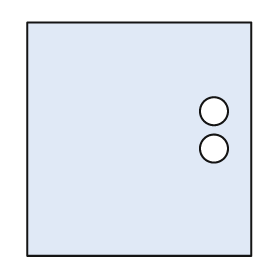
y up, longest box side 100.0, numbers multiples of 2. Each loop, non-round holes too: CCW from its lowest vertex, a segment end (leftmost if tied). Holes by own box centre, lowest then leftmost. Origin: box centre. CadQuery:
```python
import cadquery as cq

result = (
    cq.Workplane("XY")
    .moveTo(-48.0, -50.0)
    .lineTo(48.0, -50.0)
    .lineTo(48.0, 50.0)
    .lineTo(-48.0, 50.0)
    .close()
    .moveTo(32.0, -4.0)
    .circle(6.0)
    .moveTo(32.0, 12.0)
    .circle(6.0)
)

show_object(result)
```